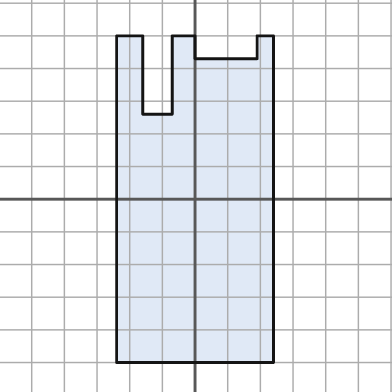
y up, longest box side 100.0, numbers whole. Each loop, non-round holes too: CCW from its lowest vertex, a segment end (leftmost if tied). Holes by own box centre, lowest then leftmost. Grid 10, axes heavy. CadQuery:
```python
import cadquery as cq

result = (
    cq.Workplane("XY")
    .moveTo(-24.0, -50.0)
    .lineTo(24.0, -50.0)
    .lineTo(24.0, 50.0)
    .lineTo(19.0, 50.0)
    .lineTo(19.0, 43.0)
    .lineTo(0.0, 43.0)
    .lineTo(0.0, 50.0)
    .lineTo(-7.0, 50.0)
    .lineTo(-7.0, 26.0)
    .lineTo(-16.0, 26.0)
    .lineTo(-16.0, 50.0)
    .lineTo(-24.0, 50.0)
    .close()
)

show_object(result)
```